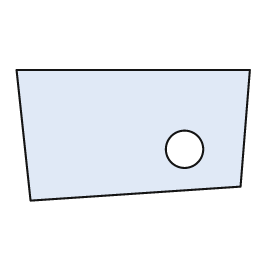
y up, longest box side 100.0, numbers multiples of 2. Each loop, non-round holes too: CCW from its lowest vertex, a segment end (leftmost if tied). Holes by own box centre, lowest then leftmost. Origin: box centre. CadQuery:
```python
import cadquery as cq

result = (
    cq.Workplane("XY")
    .moveTo(-44.0, -28.0)
    .lineTo(46.0, -22.0)
    .lineTo(50.0, 28.0)
    .lineTo(-50.0, 28.0)
    .close()
    .moveTo(22.0, -6.0)
    .circle(8.0)
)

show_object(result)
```